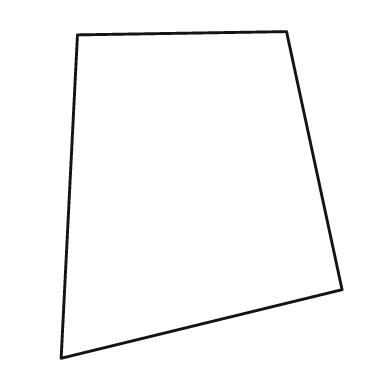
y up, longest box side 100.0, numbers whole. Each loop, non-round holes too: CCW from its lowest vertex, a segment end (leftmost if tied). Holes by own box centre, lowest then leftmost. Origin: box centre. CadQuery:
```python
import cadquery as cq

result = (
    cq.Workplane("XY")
    .moveTo(-43.0, -50.0)
    .lineTo(43.0, -29.0)
    .lineTo(26.0, 50.0)
    .lineTo(-38.0, 49.0)
    .close()
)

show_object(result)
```